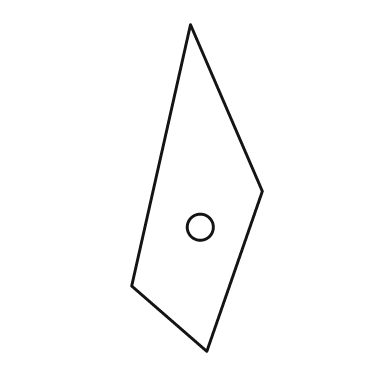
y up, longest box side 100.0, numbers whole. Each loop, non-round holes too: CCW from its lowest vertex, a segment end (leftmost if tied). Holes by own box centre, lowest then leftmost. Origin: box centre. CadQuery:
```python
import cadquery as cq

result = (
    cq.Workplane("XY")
    .moveTo(3.0, -50.0)
    .lineTo(20.0, -1.0)
    .lineTo(-2.0, 50.0)
    .lineTo(-20.0, -30.0)
    .close()
    .moveTo(1.0, -12.0)
    .circle(4.0)
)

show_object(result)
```